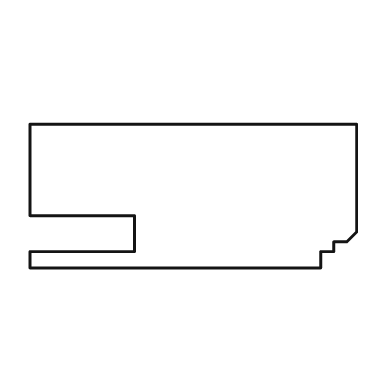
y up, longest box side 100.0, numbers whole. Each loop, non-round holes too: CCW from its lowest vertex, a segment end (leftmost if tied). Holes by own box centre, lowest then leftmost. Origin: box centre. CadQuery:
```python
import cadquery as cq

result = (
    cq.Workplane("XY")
    .moveTo(-50.0, -22.0)
    .lineTo(39.0, -22.0)
    .lineTo(39.0, -17.0)
    .lineTo(43.0, -17.0)
    .lineTo(43.0, -14.0)
    .lineTo(47.0, -14.0)
    .lineTo(50.0, -11.0)
    .lineTo(50.0, 22.0)
    .lineTo(-50.0, 22.0)
    .lineTo(-50.0, -6.0)
    .lineTo(-18.0, -6.0)
    .lineTo(-18.0, -17.0)
    .lineTo(-50.0, -17.0)
    .close()
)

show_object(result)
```